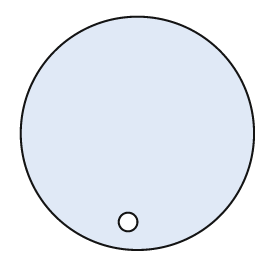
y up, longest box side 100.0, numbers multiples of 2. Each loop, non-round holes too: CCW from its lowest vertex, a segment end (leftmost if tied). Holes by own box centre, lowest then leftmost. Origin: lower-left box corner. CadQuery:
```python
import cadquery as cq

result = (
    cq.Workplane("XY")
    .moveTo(50.0, 50.0)
    .circle(50.0)
    .moveTo(46.0, 12.0)
    .circle(4.0)
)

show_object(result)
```